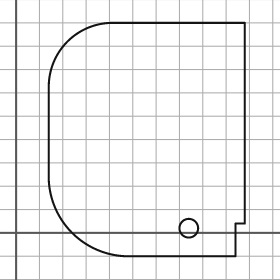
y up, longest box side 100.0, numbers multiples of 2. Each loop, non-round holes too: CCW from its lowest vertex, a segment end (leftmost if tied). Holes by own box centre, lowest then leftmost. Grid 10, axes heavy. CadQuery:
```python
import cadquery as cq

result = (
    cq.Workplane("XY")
    .moveTo(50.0, -10.0)
    .lineTo(94.0, -10.0)
    .lineTo(94.0, 4.0)
    .lineTo(98.0, 4.0)
    .lineTo(98.0, 90.0)
    .lineTo(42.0, 90.0)
    .threePointArc((22.0, 82.0), (14.0, 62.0))
    .lineTo(14.0, 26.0)
    .threePointArc((24.0, 0.0), (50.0, -10.0))
    .close()
    .moveTo(74.0, 2.0)
    .circle(4.0)
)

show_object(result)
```